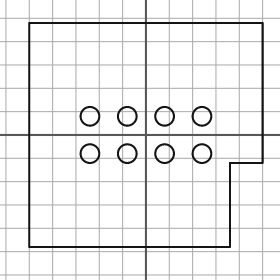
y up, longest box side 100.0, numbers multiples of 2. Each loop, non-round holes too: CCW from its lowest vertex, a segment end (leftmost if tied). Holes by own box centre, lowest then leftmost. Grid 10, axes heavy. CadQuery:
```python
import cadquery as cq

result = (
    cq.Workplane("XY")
    .moveTo(-50.0, -48.0)
    .lineTo(36.0, -48.0)
    .lineTo(36.0, -12.0)
    .lineTo(50.0, -12.0)
    .lineTo(50.0, 48.0)
    .lineTo(-50.0, 48.0)
    .close()
    .moveTo(-24.0, -8.0)
    .circle(4.0)
    .moveTo(-8.0, -8.0)
    .circle(4.0)
    .moveTo(8.0, -8.0)
    .circle(4.0)
    .moveTo(24.0, -8.0)
    .circle(4.0)
    .moveTo(-24.0, 8.0)
    .circle(4.0)
    .moveTo(-8.0, 8.0)
    .circle(4.0)
    .moveTo(8.0, 8.0)
    .circle(4.0)
    .moveTo(24.0, 8.0)
    .circle(4.0)
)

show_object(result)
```